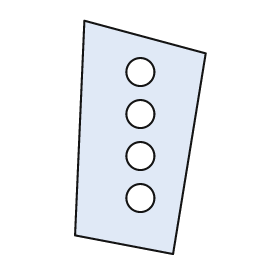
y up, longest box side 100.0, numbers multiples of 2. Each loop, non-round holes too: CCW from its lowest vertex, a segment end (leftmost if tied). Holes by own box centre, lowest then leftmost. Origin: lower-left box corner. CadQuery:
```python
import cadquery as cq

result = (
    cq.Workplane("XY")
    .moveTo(42.0, 0.0)
    .lineTo(56.0, 86.0)
    .lineTo(4.0, 100.0)
    .lineTo(0.0, 8.0)
    .close()
    .moveTo(28.0, 24.0)
    .circle(6.0)
    .moveTo(28.0, 42.0)
    .circle(6.0)
    .moveTo(28.0, 60.0)
    .circle(6.0)
    .moveTo(28.0, 78.0)
    .circle(6.0)
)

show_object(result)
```